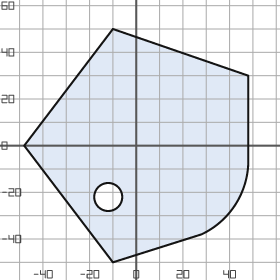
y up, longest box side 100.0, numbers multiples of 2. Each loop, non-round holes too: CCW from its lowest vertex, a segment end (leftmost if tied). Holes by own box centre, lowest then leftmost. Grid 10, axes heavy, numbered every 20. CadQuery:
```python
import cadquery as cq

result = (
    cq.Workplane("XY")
    .moveTo(-10.0, -50.0)
    .lineTo(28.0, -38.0)
    .threePointArc((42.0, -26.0), (48.0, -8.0))
    .lineTo(48.0, 30.0)
    .lineTo(-10.0, 50.0)
    .lineTo(-48.0, 0.0)
    .close()
    .moveTo(-12.0, -22.0)
    .circle(6.0)
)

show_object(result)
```